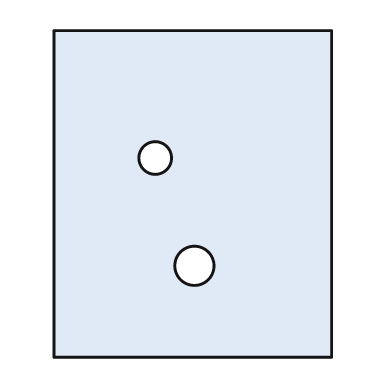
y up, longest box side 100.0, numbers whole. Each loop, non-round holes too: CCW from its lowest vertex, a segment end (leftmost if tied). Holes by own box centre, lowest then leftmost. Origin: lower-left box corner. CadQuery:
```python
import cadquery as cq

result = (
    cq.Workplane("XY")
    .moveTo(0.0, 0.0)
    .lineTo(85.0, 0.0)
    .lineTo(85.0, 100.0)
    .lineTo(0.0, 100.0)
    .close()
    .moveTo(43.0, 28.0)
    .circle(6.0)
    .moveTo(31.0, 61.0)
    .circle(5.0)
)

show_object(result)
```